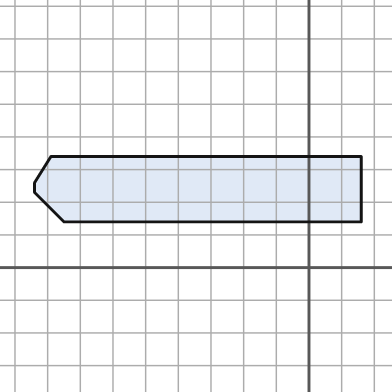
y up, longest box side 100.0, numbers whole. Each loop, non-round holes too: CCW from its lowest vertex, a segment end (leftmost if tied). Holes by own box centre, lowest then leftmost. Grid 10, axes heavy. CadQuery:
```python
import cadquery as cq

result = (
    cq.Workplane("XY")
    .moveTo(-75.0, 14.0)
    .lineTo(16.0, 14.0)
    .lineTo(16.0, 34.0)
    .lineTo(-79.0, 34.0)
    .lineTo(-84.0, 26.0)
    .lineTo(-84.0, 23.0)
    .close()
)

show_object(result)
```